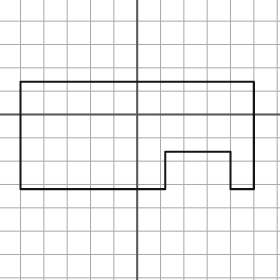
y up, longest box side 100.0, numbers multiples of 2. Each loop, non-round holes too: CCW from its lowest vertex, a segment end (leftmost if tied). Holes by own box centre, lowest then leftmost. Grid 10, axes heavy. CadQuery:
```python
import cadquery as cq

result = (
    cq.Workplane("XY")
    .moveTo(-50.0, -32.0)
    .lineTo(12.0, -32.0)
    .lineTo(12.0, -16.0)
    .lineTo(40.0, -16.0)
    .lineTo(40.0, -32.0)
    .lineTo(50.0, -32.0)
    .lineTo(50.0, 14.0)
    .lineTo(-50.0, 14.0)
    .close()
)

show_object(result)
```